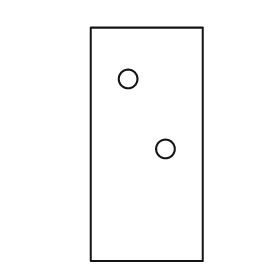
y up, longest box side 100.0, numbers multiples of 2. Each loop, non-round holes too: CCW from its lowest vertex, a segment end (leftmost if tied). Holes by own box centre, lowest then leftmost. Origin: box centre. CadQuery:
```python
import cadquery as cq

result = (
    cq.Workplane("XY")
    .moveTo(-24.0, -50.0)
    .lineTo(24.0, -50.0)
    .lineTo(24.0, 50.0)
    .lineTo(-24.0, 50.0)
    .close()
    .moveTo(8.0, -2.0)
    .circle(4.0)
    .moveTo(-8.0, 28.0)
    .circle(4.0)
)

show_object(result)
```